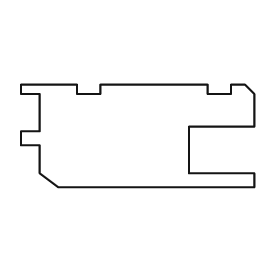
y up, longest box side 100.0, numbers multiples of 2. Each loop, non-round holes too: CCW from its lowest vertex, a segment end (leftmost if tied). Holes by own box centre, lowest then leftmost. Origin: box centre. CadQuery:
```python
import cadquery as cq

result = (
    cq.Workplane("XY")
    .moveTo(-34.0, -22.0)
    .lineTo(50.0, -22.0)
    .lineTo(50.0, -16.0)
    .lineTo(22.0, -16.0)
    .lineTo(22.0, 4.0)
    .lineTo(50.0, 4.0)
    .lineTo(50.0, 18.0)
    .lineTo(46.0, 22.0)
    .lineTo(40.0, 22.0)
    .lineTo(40.0, 18.0)
    .lineTo(30.0, 18.0)
    .lineTo(30.0, 22.0)
    .lineTo(-16.0, 22.0)
    .lineTo(-16.0, 18.0)
    .lineTo(-26.0, 18.0)
    .lineTo(-26.0, 22.0)
    .lineTo(-50.0, 22.0)
    .lineTo(-50.0, 18.0)
    .lineTo(-42.0, 18.0)
    .lineTo(-42.0, 2.0)
    .lineTo(-50.0, 2.0)
    .lineTo(-50.0, -4.0)
    .lineTo(-42.0, -4.0)
    .lineTo(-42.0, -16.0)
    .close()
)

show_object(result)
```